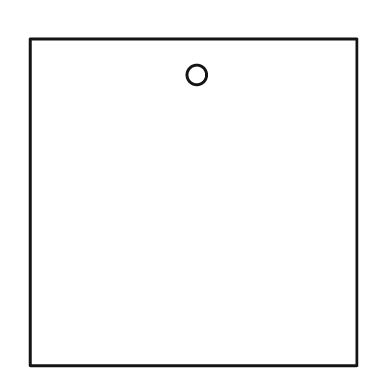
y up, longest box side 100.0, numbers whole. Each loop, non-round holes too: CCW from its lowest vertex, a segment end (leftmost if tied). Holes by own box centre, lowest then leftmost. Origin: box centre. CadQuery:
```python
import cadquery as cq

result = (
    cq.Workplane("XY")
    .moveTo(-50.0, -50.0)
    .lineTo(50.0, -50.0)
    .lineTo(50.0, 50.0)
    .lineTo(-50.0, 50.0)
    .close()
    .moveTo(1.0, 39.0)
    .circle(3.0)
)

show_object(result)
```